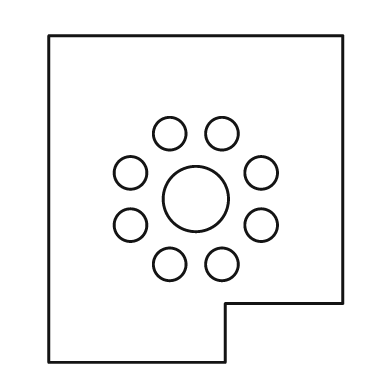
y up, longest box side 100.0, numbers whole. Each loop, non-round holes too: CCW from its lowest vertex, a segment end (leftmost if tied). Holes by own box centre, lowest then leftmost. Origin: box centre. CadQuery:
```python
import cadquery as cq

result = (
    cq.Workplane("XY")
    .moveTo(-45.0, -50.0)
    .lineTo(9.0, -50.0)
    .lineTo(9.0, -32.0)
    .lineTo(45.0, -32.0)
    .lineTo(45.0, 50.0)
    .lineTo(-45.0, 50.0)
    .close()
    .moveTo(-8.0, -20.0)
    .circle(5.0)
    .moveTo(8.0, -20.0)
    .circle(5.0)
    .moveTo(-20.0, -8.0)
    .circle(5.0)
    .moveTo(20.0, -8.0)
    .circle(5.0)
    .moveTo(0.0, 0.0)
    .circle(10.0)
    .moveTo(-20.0, 8.0)
    .circle(5.0)
    .moveTo(20.0, 8.0)
    .circle(5.0)
    .moveTo(-8.0, 20.0)
    .circle(5.0)
    .moveTo(8.0, 20.0)
    .circle(5.0)
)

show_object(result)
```